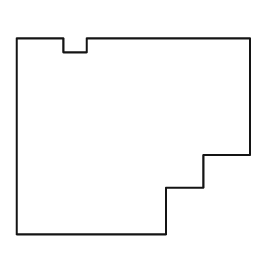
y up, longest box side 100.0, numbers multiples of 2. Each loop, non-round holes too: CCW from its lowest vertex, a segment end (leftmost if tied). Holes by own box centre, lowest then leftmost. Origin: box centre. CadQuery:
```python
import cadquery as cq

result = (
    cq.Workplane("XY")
    .moveTo(-50.0, -42.0)
    .lineTo(14.0, -42.0)
    .lineTo(14.0, -22.0)
    .lineTo(30.0, -22.0)
    .lineTo(30.0, -8.0)
    .lineTo(50.0, -8.0)
    .lineTo(50.0, 42.0)
    .lineTo(-20.0, 42.0)
    .lineTo(-20.0, 36.0)
    .lineTo(-30.0, 36.0)
    .lineTo(-30.0, 42.0)
    .lineTo(-50.0, 42.0)
    .close()
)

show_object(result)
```